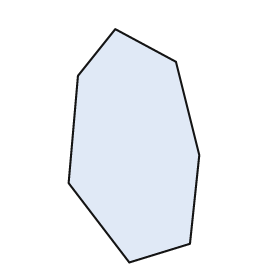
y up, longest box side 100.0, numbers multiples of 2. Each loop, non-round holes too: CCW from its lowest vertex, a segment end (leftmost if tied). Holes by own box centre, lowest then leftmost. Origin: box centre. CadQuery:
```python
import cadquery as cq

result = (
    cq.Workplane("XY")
    .moveTo(-2.0, -50.0)
    .lineTo(24.0, -42.0)
    .lineTo(28.0, -4.0)
    .lineTo(18.0, 36.0)
    .lineTo(-8.0, 50.0)
    .lineTo(-24.0, 30.0)
    .lineTo(-28.0, -16.0)
    .close()
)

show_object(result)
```